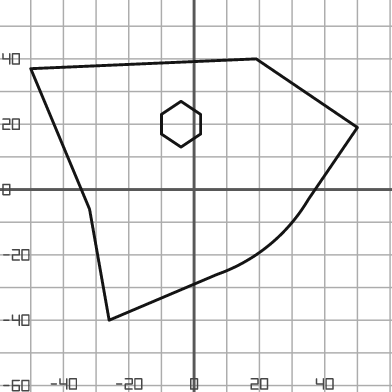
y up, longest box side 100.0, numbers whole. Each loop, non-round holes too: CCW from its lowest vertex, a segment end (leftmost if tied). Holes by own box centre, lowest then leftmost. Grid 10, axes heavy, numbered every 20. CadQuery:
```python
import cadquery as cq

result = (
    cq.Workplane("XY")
    .moveTo(-26.0, -40.0)
    .lineTo(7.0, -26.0)
    .threePointArc((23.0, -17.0), (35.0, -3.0))
    .lineTo(50.0, 19.0)
    .lineTo(19.0, 40.0)
    .lineTo(-50.0, 37.0)
    .lineTo(-32.0, -6.0)
    .close()
    .moveTo(-4.0, 13.0)
    .lineTo(2.0, 17.0)
    .lineTo(2.0, 23.0)
    .lineTo(-4.0, 27.0)
    .lineTo(-10.0, 23.0)
    .lineTo(-10.0, 17.0)
    .close()
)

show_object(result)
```